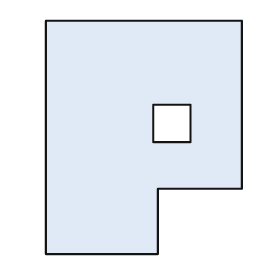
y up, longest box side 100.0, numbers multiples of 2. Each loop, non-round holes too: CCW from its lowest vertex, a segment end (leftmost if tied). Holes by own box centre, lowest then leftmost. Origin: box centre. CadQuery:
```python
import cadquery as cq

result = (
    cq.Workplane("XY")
    .moveTo(-42.0, -50.0)
    .lineTo(6.0, -50.0)
    .lineTo(6.0, -22.0)
    .lineTo(42.0, -22.0)
    .lineTo(42.0, 50.0)
    .lineTo(-42.0, 50.0)
    .close()
    .moveTo(4.0, -2.0)
    .lineTo(20.0, -2.0)
    .lineTo(20.0, 14.0)
    .lineTo(4.0, 14.0)
    .close()
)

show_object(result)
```